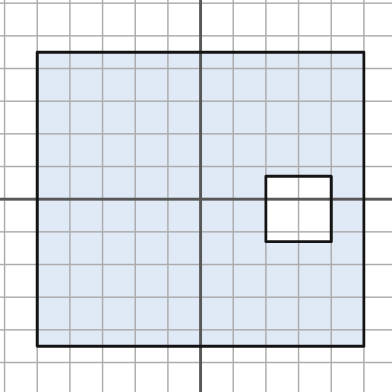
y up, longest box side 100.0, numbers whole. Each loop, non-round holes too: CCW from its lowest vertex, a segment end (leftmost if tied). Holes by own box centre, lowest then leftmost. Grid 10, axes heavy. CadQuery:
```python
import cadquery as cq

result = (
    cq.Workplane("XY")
    .moveTo(-50.0, -45.0)
    .lineTo(50.0, -45.0)
    .lineTo(50.0, 45.0)
    .lineTo(-50.0, 45.0)
    .close()
    .moveTo(20.0, -13.0)
    .lineTo(40.0, -13.0)
    .lineTo(40.0, 7.0)
    .lineTo(20.0, 7.0)
    .close()
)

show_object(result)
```